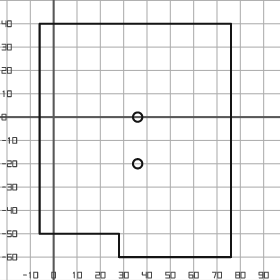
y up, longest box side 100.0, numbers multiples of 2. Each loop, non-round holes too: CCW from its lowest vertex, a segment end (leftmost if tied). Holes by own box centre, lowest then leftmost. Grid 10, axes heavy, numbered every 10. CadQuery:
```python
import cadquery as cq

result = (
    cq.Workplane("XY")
    .moveTo(28.0, -60.0)
    .lineTo(76.0, -60.0)
    .lineTo(76.0, 40.0)
    .lineTo(-6.0, 40.0)
    .lineTo(-6.0, -50.0)
    .lineTo(28.0, -50.0)
    .close()
    .moveTo(36.0, -20.0)
    .circle(2.0)
    .moveTo(36.0, 0.0)
    .circle(2.0)
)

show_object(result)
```